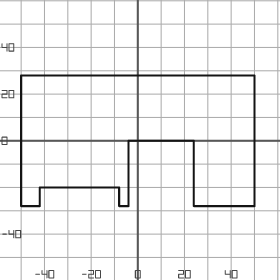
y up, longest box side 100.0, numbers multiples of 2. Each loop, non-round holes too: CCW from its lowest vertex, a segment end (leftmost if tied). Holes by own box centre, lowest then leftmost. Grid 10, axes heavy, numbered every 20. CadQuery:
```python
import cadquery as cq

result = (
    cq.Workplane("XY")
    .moveTo(-50.0, -28.0)
    .lineTo(-42.0, -28.0)
    .lineTo(-42.0, -20.0)
    .lineTo(-8.0, -20.0)
    .lineTo(-8.0, -28.0)
    .lineTo(-4.0, -28.0)
    .lineTo(-4.0, 0.0)
    .lineTo(24.0, 0.0)
    .lineTo(24.0, -28.0)
    .lineTo(50.0, -28.0)
    .lineTo(50.0, 28.0)
    .lineTo(-50.0, 28.0)
    .close()
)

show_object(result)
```